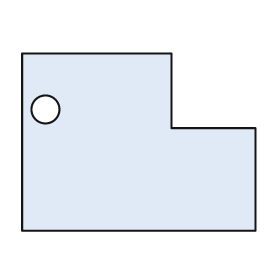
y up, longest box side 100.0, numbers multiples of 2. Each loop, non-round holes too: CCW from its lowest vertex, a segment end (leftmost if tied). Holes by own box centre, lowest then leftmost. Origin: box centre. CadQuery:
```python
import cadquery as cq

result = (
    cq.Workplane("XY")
    .moveTo(-50.0, -38.0)
    .lineTo(50.0, -38.0)
    .lineTo(50.0, 6.0)
    .lineTo(14.0, 6.0)
    .lineTo(14.0, 38.0)
    .lineTo(-50.0, 38.0)
    .close()
    .moveTo(-40.0, 14.0)
    .circle(6.0)
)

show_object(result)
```